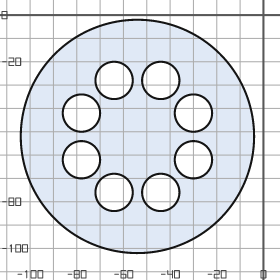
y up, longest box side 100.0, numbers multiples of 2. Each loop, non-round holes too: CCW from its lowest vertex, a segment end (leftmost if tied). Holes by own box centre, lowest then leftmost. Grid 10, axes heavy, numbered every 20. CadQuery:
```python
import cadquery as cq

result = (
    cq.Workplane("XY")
    .moveTo(-54.0, -52.0)
    .circle(50.0)
    .moveTo(-64.0, -76.0)
    .circle(8.0)
    .moveTo(-44.0, -76.0)
    .circle(8.0)
    .moveTo(-78.0, -62.0)
    .circle(8.0)
    .moveTo(-30.0, -62.0)
    .circle(8.0)
    .moveTo(-78.0, -42.0)
    .circle(8.0)
    .moveTo(-30.0, -42.0)
    .circle(8.0)
    .moveTo(-64.0, -28.0)
    .circle(8.0)
    .moveTo(-44.0, -28.0)
    .circle(8.0)
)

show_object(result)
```